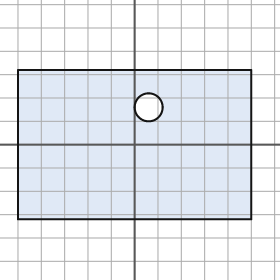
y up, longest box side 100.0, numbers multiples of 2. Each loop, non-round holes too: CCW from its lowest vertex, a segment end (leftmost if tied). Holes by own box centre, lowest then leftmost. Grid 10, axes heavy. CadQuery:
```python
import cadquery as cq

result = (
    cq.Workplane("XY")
    .moveTo(-50.0, -32.0)
    .lineTo(50.0, -32.0)
    .lineTo(50.0, 32.0)
    .lineTo(-50.0, 32.0)
    .close()
    .moveTo(6.0, 16.0)
    .circle(6.0)
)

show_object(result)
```